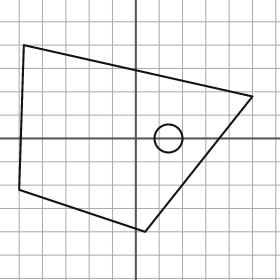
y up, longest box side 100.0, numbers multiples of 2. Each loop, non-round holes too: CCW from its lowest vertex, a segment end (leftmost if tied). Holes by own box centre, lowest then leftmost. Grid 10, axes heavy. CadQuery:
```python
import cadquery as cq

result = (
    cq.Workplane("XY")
    .moveTo(4.0, -40.0)
    .lineTo(50.0, 18.0)
    .lineTo(-48.0, 40.0)
    .lineTo(-50.0, -22.0)
    .close()
    .moveTo(14.0, 0.0)
    .circle(6.0)
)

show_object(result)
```